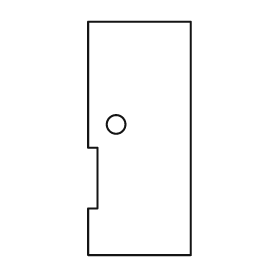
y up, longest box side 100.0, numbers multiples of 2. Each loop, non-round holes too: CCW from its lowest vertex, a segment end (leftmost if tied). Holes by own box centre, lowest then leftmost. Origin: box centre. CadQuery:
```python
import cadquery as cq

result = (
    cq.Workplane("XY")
    .moveTo(-22.0, -50.0)
    .lineTo(22.0, -50.0)
    .lineTo(22.0, 50.0)
    .lineTo(-22.0, 50.0)
    .lineTo(-22.0, -4.0)
    .lineTo(-18.0, -4.0)
    .lineTo(-18.0, -30.0)
    .lineTo(-22.0, -30.0)
    .close()
    .moveTo(-10.0, 6.0)
    .circle(4.0)
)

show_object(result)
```